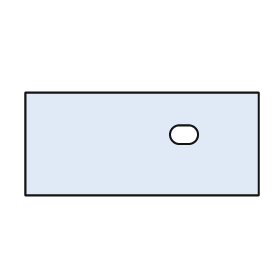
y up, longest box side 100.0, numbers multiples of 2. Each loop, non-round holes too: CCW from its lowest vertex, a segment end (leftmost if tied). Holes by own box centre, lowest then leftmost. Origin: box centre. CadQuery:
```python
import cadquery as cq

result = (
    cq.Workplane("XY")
    .moveTo(-50.0, -22.0)
    .lineTo(50.0, -22.0)
    .lineTo(50.0, 22.0)
    .lineTo(-50.0, 22.0)
    .close()
    .moveTo(16.0, 0.0)
    .lineTo(20.0, 0.0)
    .threePointArc((24.0, 4.0), (20.0, 8.0))
    .lineTo(16.0, 8.0)
    .threePointArc((12.0, 4.0), (16.0, 0.0))
    .close()
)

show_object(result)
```